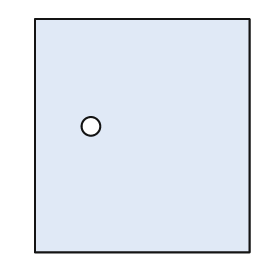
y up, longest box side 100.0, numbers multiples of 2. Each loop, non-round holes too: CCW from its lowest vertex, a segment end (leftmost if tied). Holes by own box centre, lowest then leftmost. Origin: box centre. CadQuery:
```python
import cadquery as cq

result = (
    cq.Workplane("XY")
    .moveTo(-46.0, -50.0)
    .lineTo(46.0, -50.0)
    .lineTo(46.0, 50.0)
    .lineTo(-46.0, 50.0)
    .close()
    .moveTo(-22.0, 4.0)
    .circle(4.0)
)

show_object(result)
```